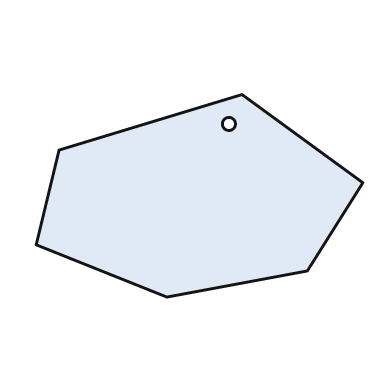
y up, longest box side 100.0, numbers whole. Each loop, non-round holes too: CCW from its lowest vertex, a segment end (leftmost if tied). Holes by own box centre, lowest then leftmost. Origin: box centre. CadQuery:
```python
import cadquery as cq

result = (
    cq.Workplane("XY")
    .moveTo(-10.0, -31.0)
    .lineTo(33.0, -23.0)
    .lineTo(50.0, 4.0)
    .lineTo(13.0, 31.0)
    .lineTo(-43.0, 14.0)
    .lineTo(-50.0, -15.0)
    .close()
    .moveTo(9.0, 22.0)
    .circle(2.0)
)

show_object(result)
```